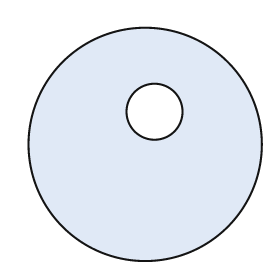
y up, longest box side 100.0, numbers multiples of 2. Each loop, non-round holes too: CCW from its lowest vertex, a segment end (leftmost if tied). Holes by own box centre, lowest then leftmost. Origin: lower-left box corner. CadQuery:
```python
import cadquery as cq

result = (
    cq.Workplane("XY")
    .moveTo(50.0, 50.0)
    .circle(50.0)
    .moveTo(54.0, 64.0)
    .circle(12.0)
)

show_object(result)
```